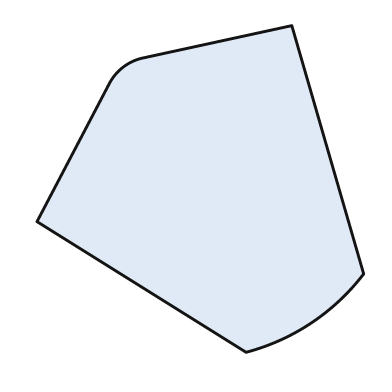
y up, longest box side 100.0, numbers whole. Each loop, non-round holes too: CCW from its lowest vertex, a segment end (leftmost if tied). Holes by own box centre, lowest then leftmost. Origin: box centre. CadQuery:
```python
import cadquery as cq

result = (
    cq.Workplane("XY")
    .moveTo(14.0, -50.0)
    .threePointArc((34.0, -41.0), (50.0, -26.0))
    .lineTo(28.0, 50.0)
    .lineTo(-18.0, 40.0)
    .threePointArc((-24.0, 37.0), (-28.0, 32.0))
    .lineTo(-50.0, -10.0)
    .close()
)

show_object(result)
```